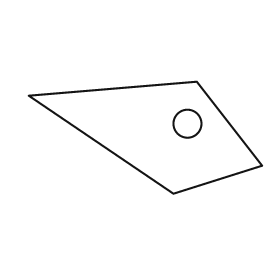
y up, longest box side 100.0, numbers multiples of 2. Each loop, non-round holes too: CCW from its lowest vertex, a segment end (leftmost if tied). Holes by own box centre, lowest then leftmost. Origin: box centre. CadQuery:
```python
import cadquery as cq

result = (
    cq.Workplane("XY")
    .moveTo(12.0, -24.0)
    .lineTo(50.0, -12.0)
    .lineTo(22.0, 24.0)
    .lineTo(-50.0, 18.0)
    .close()
    .moveTo(18.0, 6.0)
    .circle(6.0)
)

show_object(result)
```